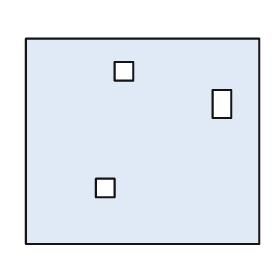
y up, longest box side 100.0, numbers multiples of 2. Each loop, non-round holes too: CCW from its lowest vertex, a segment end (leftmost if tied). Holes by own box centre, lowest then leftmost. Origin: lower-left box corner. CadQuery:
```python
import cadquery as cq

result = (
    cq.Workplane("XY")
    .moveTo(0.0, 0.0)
    .lineTo(100.0, 0.0)
    .lineTo(100.0, 88.0)
    .lineTo(0.0, 88.0)
    .close()
    .moveTo(30.0, 20.0)
    .lineTo(38.0, 20.0)
    .lineTo(38.0, 28.0)
    .lineTo(30.0, 28.0)
    .close()
    .moveTo(80.0, 54.0)
    .lineTo(88.0, 54.0)
    .lineTo(88.0, 66.0)
    .lineTo(80.0, 66.0)
    .close()
    .moveTo(38.0, 70.0)
    .lineTo(46.0, 70.0)
    .lineTo(46.0, 78.0)
    .lineTo(38.0, 78.0)
    .close()
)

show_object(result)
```